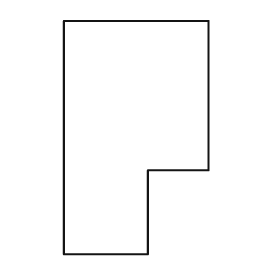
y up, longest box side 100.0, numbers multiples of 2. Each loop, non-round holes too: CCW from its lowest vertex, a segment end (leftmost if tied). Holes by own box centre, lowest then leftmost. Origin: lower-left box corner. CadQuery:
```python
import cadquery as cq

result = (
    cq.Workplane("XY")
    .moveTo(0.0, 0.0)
    .lineTo(36.0, 0.0)
    .lineTo(36.0, 36.0)
    .lineTo(62.0, 36.0)
    .lineTo(62.0, 100.0)
    .lineTo(0.0, 100.0)
    .close()
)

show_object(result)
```